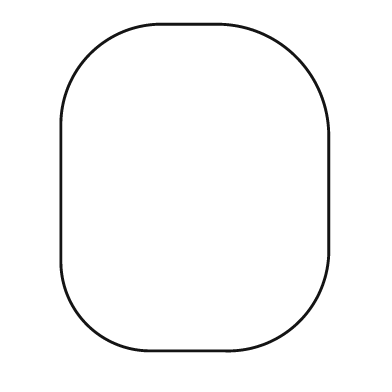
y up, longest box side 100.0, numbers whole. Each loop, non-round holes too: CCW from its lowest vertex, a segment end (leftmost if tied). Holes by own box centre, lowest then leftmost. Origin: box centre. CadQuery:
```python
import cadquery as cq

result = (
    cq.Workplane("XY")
    .moveTo(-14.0, -50.0)
    .lineTo(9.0, -50.0)
    .threePointArc((32.0, -41.0), (41.0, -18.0))
    .lineTo(41.0, 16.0)
    .threePointArc((31.0, 40.0), (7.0, 50.0))
    .lineTo(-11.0, 50.0)
    .threePointArc((-32.0, 41.0), (-41.0, 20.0))
    .lineTo(-41.0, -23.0)
    .threePointArc((-33.0, -42.0), (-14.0, -50.0))
    .close()
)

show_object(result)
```